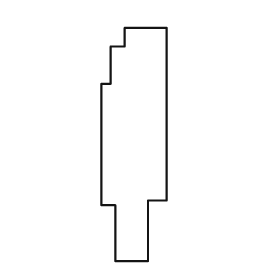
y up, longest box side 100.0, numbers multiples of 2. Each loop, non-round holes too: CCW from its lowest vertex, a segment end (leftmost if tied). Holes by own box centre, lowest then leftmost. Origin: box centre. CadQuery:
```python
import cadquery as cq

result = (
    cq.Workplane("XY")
    .moveTo(-8.0, -50.0)
    .lineTo(6.0, -50.0)
    .lineTo(6.0, -24.0)
    .lineTo(14.0, -24.0)
    .lineTo(14.0, 50.0)
    .lineTo(-4.0, 50.0)
    .lineTo(-4.0, 42.0)
    .lineTo(-10.0, 42.0)
    .lineTo(-10.0, 26.0)
    .lineTo(-14.0, 26.0)
    .lineTo(-14.0, -26.0)
    .lineTo(-8.0, -26.0)
    .close()
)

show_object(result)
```